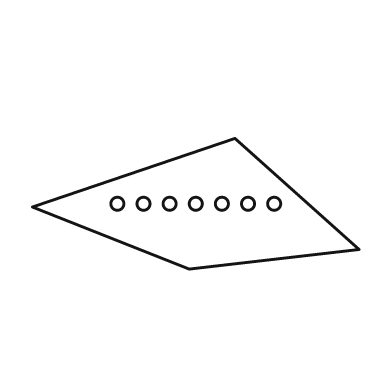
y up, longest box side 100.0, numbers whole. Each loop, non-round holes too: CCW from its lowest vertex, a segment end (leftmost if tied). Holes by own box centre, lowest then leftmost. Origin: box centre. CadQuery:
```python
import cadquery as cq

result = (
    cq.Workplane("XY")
    .moveTo(-2.0, -20.0)
    .lineTo(50.0, -14.0)
    .lineTo(12.0, 20.0)
    .lineTo(-50.0, -1.0)
    .close()
    .moveTo(-24.0, 0.0)
    .circle(2.0)
    .moveTo(-16.0, 0.0)
    .circle(2.0)
    .moveTo(-8.0, 0.0)
    .circle(2.0)
    .moveTo(0.0, 0.0)
    .circle(2.0)
    .moveTo(8.0, 0.0)
    .circle(2.0)
    .moveTo(16.0, 0.0)
    .circle(2.0)
    .moveTo(24.0, 0.0)
    .circle(2.0)
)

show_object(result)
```